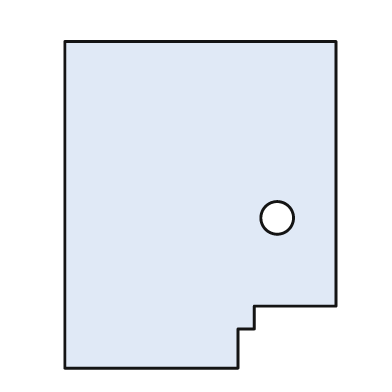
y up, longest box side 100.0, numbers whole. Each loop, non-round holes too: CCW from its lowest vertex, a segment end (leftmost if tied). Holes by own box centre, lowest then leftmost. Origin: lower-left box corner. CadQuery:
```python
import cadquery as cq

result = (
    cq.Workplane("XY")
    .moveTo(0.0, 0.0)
    .lineTo(53.0, 0.0)
    .lineTo(53.0, 12.0)
    .lineTo(58.0, 12.0)
    .lineTo(58.0, 19.0)
    .lineTo(83.0, 19.0)
    .lineTo(83.0, 100.0)
    .lineTo(0.0, 100.0)
    .close()
    .moveTo(65.0, 46.0)
    .circle(5.0)
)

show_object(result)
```